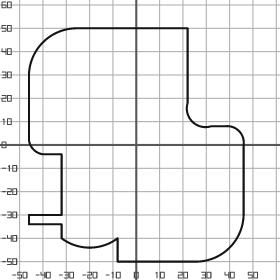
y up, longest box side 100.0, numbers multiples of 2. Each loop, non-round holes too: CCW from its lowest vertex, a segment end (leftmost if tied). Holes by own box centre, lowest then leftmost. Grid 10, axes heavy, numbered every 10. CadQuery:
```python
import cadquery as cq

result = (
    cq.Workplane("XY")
    .moveTo(-8.0, -50.0)
    .lineTo(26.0, -50.0)
    .threePointArc((40.0, -44.0), (46.0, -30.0))
    .lineTo(46.0, 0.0)
    .threePointArc((44.0, 6.0), (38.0, 8.0))
    .lineTo(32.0, 8.0)
    .threePointArc((24.0, 10.0), (22.0, 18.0))
    .lineTo(22.0, 50.0)
    .lineTo(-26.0, 50.0)
    .threePointArc((-40.0, 44.0), (-46.0, 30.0))
    .lineTo(-46.0, 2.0)
    .threePointArc((-44.0, -2.0), (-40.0, -4.0))
    .lineTo(-32.0, -4.0)
    .lineTo(-32.0, -30.0)
    .lineTo(-46.0, -30.0)
    .lineTo(-46.0, -34.0)
    .lineTo(-32.0, -34.0)
    .lineTo(-32.0, -40.0)
    .threePointArc((-20.0, -44.0), (-8.0, -40.0))
    .close()
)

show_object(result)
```